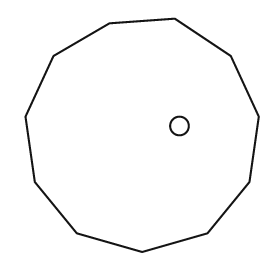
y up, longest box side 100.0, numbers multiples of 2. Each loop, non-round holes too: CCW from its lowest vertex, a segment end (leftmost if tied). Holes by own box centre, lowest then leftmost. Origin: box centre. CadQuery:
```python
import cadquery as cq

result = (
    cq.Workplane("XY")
    .moveTo(0.0, -50.0)
    .lineTo(28.0, -42.0)
    .lineTo(46.0, -20.0)
    .lineTo(50.0, 8.0)
    .lineTo(38.0, 34.0)
    .lineTo(14.0, 50.0)
    .lineTo(-14.0, 48.0)
    .lineTo(-38.0, 34.0)
    .lineTo(-50.0, 8.0)
    .lineTo(-46.0, -20.0)
    .lineTo(-28.0, -42.0)
    .close()
    .moveTo(16.0, 4.0)
    .circle(4.0)
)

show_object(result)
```